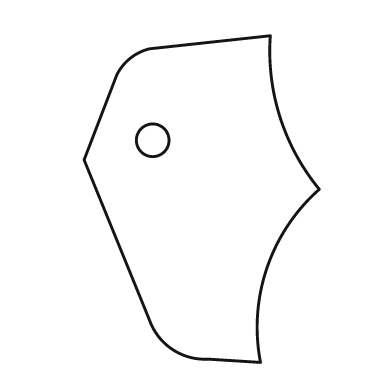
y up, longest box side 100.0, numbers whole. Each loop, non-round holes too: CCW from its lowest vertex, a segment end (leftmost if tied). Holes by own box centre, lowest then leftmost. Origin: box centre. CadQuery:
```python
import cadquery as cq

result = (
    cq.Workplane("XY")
    .moveTo(18.0, -50.0)
    .threePointArc((20.0, -21.0), (36.0, 3.0))
    .threePointArc((24.0, 25.0), (21.0, 50.0))
    .lineTo(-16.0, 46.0)
    .threePointArc((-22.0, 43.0), (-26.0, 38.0))
    .lineTo(-36.0, 12.0)
    .lineTo(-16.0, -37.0)
    .threePointArc((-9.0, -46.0), (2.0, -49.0))
    .close()
    .moveTo(-15.0, 18.0)
    .circle(5.0)
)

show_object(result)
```